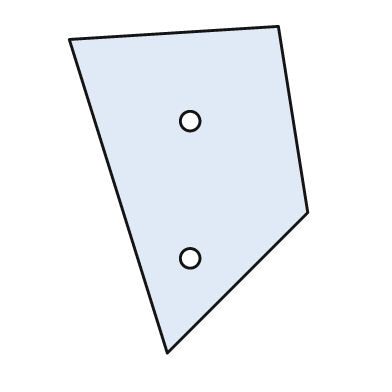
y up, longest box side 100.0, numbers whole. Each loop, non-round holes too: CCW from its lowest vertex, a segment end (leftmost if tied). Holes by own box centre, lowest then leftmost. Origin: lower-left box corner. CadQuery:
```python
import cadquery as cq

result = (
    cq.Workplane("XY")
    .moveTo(30.0, 0.0)
    .lineTo(73.0, 43.0)
    .lineTo(64.0, 100.0)
    .lineTo(0.0, 96.0)
    .close()
    .moveTo(37.0, 29.0)
    .circle(3.0)
    .moveTo(37.0, 71.0)
    .circle(3.0)
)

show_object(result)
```